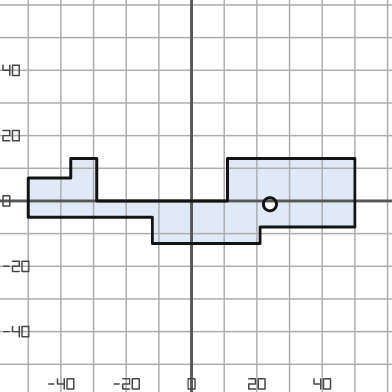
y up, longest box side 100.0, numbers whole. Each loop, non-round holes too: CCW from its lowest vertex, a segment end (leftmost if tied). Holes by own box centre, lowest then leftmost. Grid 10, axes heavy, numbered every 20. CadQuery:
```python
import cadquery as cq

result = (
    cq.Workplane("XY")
    .moveTo(-12.0, -13.0)
    .lineTo(21.0, -13.0)
    .lineTo(21.0, -8.0)
    .lineTo(50.0, -8.0)
    .lineTo(50.0, 13.0)
    .lineTo(11.0, 13.0)
    .lineTo(11.0, 0.0)
    .lineTo(-29.0, 0.0)
    .lineTo(-29.0, 13.0)
    .lineTo(-37.0, 13.0)
    .lineTo(-37.0, 7.0)
    .lineTo(-50.0, 7.0)
    .lineTo(-50.0, -5.0)
    .lineTo(-12.0, -5.0)
    .close()
    .moveTo(24.0, -1.0)
    .circle(2.0)
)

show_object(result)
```